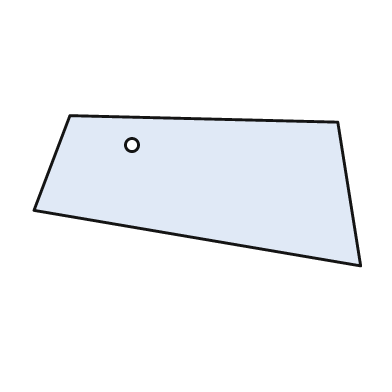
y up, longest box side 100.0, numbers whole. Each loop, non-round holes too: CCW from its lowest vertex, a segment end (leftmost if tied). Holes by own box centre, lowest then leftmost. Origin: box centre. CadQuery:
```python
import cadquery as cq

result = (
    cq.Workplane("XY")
    .moveTo(50.0, -23.0)
    .lineTo(43.0, 21.0)
    .lineTo(-39.0, 23.0)
    .lineTo(-50.0, -6.0)
    .close()
    .moveTo(-20.0, 14.0)
    .circle(2.0)
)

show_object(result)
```